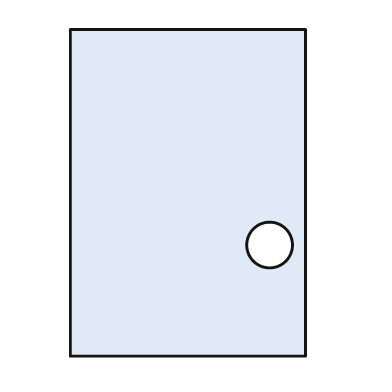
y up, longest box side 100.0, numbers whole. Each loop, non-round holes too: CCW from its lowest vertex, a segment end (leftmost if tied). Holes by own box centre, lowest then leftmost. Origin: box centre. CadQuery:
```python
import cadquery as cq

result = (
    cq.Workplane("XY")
    .moveTo(-36.0, -50.0)
    .lineTo(36.0, -50.0)
    .lineTo(36.0, 50.0)
    .lineTo(-36.0, 50.0)
    .close()
    .moveTo(25.0, -16.0)
    .circle(7.0)
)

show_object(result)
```